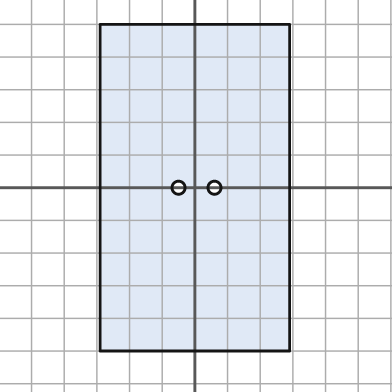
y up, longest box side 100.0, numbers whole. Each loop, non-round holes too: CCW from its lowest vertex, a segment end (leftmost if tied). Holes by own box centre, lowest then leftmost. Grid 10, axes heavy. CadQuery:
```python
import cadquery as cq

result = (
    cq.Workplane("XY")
    .moveTo(-29.0, -50.0)
    .lineTo(29.0, -50.0)
    .lineTo(29.0, 50.0)
    .lineTo(-29.0, 50.0)
    .close()
    .moveTo(-5.0, 0.0)
    .circle(2.0)
    .moveTo(6.0, 0.0)
    .circle(2.0)
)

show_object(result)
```